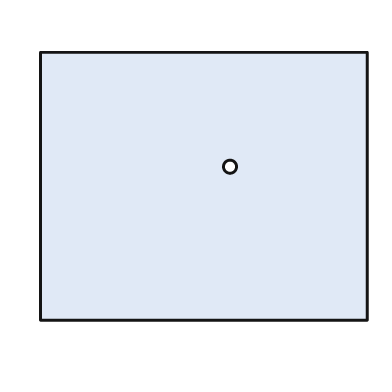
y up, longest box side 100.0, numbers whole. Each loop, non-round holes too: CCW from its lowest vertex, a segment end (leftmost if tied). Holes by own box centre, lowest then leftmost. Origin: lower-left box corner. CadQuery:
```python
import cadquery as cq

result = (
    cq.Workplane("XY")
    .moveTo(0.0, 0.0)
    .lineTo(100.0, 0.0)
    .lineTo(100.0, 82.0)
    .lineTo(0.0, 82.0)
    .close()
    .moveTo(58.0, 47.0)
    .circle(2.0)
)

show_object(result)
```